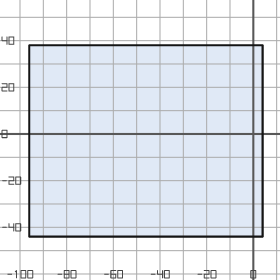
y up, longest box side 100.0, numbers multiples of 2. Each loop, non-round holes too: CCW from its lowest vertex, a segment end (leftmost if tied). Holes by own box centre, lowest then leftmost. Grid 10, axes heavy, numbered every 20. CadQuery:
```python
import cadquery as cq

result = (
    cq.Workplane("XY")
    .moveTo(-96.0, -44.0)
    .lineTo(4.0, -44.0)
    .lineTo(4.0, 38.0)
    .lineTo(-96.0, 38.0)
    .close()
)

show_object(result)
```